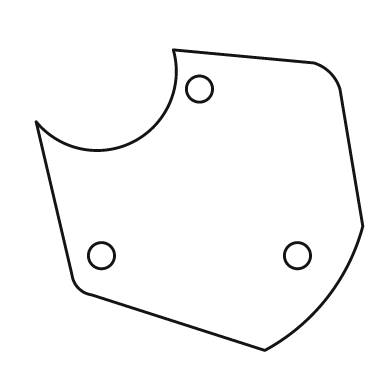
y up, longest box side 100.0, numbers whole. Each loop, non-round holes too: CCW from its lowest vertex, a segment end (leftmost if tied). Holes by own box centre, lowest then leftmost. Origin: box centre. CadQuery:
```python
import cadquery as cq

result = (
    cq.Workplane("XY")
    .moveTo(20.0, -46.0)
    .threePointArc((39.0, -30.0), (50.0, -8.0))
    .lineTo(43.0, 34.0)
    .threePointArc((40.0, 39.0), (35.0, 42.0))
    .lineTo(-8.0, 46.0)
    .threePointArc((-20.0, 18.0), (-50.0, 24.0))
    .lineTo(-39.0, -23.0)
    .threePointArc((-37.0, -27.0), (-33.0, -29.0))
    .close()
    .moveTo(-30.0, -17.0)
    .circle(4.0)
    .moveTo(30.0, -17.0)
    .circle(4.0)
    .moveTo(0.0, 34.0)
    .circle(4.0)
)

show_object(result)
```